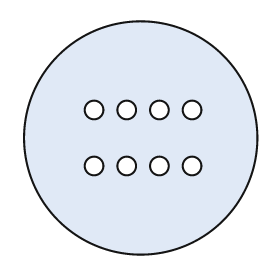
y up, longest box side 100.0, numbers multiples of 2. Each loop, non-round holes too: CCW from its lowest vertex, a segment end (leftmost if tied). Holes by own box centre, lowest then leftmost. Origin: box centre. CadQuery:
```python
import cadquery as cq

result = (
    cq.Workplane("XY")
    .moveTo(0.0, 0.0)
    .circle(50.0)
    .moveTo(-20.0, -12.0)
    .circle(4.0)
    .moveTo(-6.0, -12.0)
    .circle(4.0)
    .moveTo(8.0, -12.0)
    .circle(4.0)
    .moveTo(22.0, -12.0)
    .circle(4.0)
    .moveTo(-20.0, 12.0)
    .circle(4.0)
    .moveTo(-6.0, 12.0)
    .circle(4.0)
    .moveTo(8.0, 12.0)
    .circle(4.0)
    .moveTo(22.0, 12.0)
    .circle(4.0)
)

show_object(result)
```